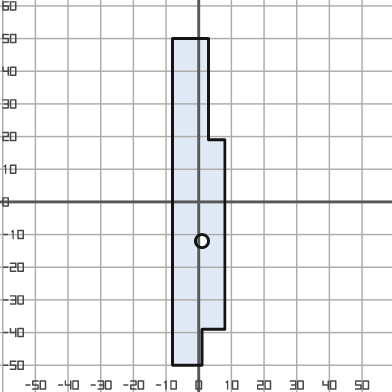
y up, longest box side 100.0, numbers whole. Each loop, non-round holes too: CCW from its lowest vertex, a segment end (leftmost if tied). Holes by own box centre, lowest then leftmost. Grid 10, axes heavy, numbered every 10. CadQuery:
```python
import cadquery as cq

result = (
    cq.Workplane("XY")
    .moveTo(-8.0, -50.0)
    .lineTo(1.0, -50.0)
    .lineTo(1.0, -39.0)
    .lineTo(8.0, -39.0)
    .lineTo(8.0, 19.0)
    .lineTo(3.0, 19.0)
    .lineTo(3.0, 50.0)
    .lineTo(-8.0, 50.0)
    .close()
    .moveTo(1.0, -12.0)
    .circle(2.0)
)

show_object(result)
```